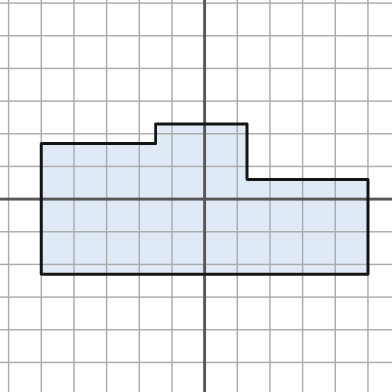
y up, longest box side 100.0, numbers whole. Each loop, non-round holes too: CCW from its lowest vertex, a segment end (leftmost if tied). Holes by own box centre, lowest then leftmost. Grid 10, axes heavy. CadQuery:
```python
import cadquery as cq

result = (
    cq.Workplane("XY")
    .moveTo(-50.0, -23.0)
    .lineTo(50.0, -23.0)
    .lineTo(50.0, 6.0)
    .lineTo(13.0, 6.0)
    .lineTo(13.0, 23.0)
    .lineTo(-15.0, 23.0)
    .lineTo(-15.0, 17.0)
    .lineTo(-50.0, 17.0)
    .close()
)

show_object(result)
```